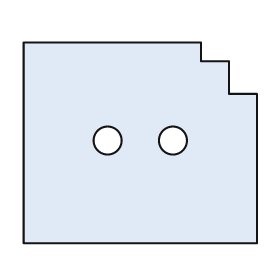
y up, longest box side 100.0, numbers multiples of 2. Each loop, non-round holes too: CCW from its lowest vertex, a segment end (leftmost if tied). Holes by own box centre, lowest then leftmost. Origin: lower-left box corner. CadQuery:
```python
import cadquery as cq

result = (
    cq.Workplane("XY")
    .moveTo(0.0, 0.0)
    .lineTo(100.0, 0.0)
    .lineTo(100.0, 64.0)
    .lineTo(88.0, 64.0)
    .lineTo(88.0, 78.0)
    .lineTo(76.0, 78.0)
    .lineTo(76.0, 86.0)
    .lineTo(0.0, 86.0)
    .close()
    .moveTo(36.0, 44.0)
    .circle(6.0)
    .moveTo(64.0, 44.0)
    .circle(6.0)
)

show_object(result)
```